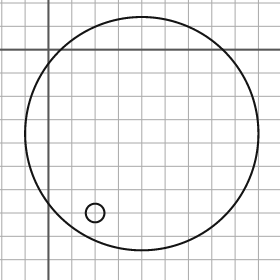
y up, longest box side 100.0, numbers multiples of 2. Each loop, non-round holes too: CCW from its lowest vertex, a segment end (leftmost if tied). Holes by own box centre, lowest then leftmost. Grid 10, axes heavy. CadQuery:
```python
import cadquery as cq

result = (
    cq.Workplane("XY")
    .moveTo(40.0, -36.0)
    .circle(50.0)
    .moveTo(20.0, -70.0)
    .circle(4.0)
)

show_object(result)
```